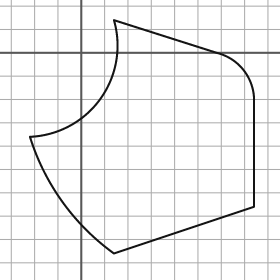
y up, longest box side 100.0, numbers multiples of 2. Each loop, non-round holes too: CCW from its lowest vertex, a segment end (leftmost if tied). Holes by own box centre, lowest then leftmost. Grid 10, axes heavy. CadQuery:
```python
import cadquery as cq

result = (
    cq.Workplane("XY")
    .moveTo(14.0, -86.0)
    .lineTo(74.0, -66.0)
    .lineTo(74.0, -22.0)
    .threePointArc((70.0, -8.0), (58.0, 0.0))
    .lineTo(14.0, 14.0)
    .threePointArc((8.0, -20.0), (-22.0, -36.0))
    .threePointArc((-8.0, -64.0), (14.0, -86.0))
    .close()
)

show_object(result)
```